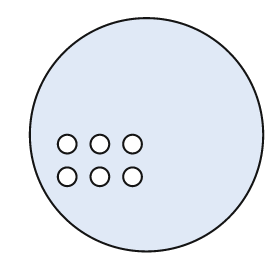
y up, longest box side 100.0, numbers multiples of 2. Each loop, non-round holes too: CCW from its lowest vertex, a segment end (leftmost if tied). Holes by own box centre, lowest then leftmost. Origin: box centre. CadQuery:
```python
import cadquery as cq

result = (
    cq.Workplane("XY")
    .moveTo(0.0, 0.0)
    .circle(50.0)
    .moveTo(-34.0, -18.0)
    .circle(4.0)
    .moveTo(-20.0, -18.0)
    .circle(4.0)
    .moveTo(-6.0, -18.0)
    .circle(4.0)
    .moveTo(-34.0, -4.0)
    .circle(4.0)
    .moveTo(-20.0, -4.0)
    .circle(4.0)
    .moveTo(-6.0, -4.0)
    .circle(4.0)
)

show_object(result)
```